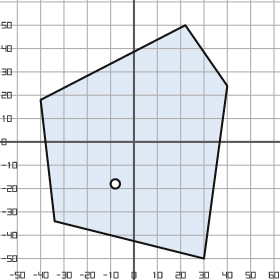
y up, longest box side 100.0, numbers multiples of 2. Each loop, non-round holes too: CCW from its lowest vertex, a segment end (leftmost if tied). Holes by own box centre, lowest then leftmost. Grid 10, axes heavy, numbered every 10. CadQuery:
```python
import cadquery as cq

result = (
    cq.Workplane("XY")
    .moveTo(30.0, -50.0)
    .lineTo(40.0, 24.0)
    .lineTo(22.0, 50.0)
    .lineTo(-40.0, 18.0)
    .lineTo(-34.0, -34.0)
    .close()
    .moveTo(-8.0, -18.0)
    .circle(2.0)
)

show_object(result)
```